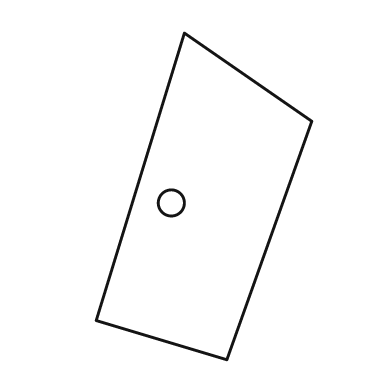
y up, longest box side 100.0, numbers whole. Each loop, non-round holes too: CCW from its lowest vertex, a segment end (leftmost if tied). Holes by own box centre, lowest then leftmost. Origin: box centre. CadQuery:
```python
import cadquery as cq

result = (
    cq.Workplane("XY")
    .moveTo(7.0, -50.0)
    .lineTo(33.0, 23.0)
    .lineTo(-6.0, 50.0)
    .lineTo(-33.0, -38.0)
    .close()
    .moveTo(-10.0, -2.0)
    .circle(4.0)
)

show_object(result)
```